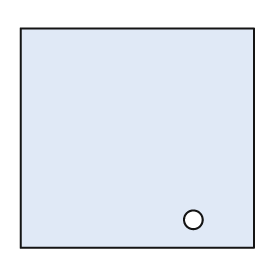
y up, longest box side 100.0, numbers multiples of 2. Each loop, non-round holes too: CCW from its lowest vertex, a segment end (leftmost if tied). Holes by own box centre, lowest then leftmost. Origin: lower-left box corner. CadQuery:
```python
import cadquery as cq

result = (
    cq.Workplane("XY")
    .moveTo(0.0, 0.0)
    .lineTo(100.0, 0.0)
    .lineTo(100.0, 94.0)
    .lineTo(0.0, 94.0)
    .close()
    .moveTo(74.0, 12.0)
    .circle(4.0)
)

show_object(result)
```